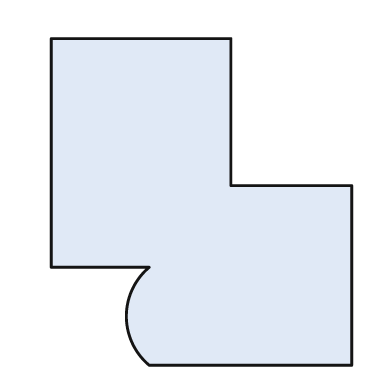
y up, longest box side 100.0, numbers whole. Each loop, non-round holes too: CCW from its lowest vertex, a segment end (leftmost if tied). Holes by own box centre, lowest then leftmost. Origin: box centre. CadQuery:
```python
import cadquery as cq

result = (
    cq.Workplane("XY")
    .moveTo(-16.0, -50.0)
    .lineTo(46.0, -50.0)
    .lineTo(46.0, 5.0)
    .lineTo(9.0, 5.0)
    .lineTo(9.0, 50.0)
    .lineTo(-46.0, 50.0)
    .lineTo(-46.0, -20.0)
    .lineTo(-16.0, -20.0)
    .threePointArc((-23.0, -35.0), (-16.0, -50.0))
    .close()
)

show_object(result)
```